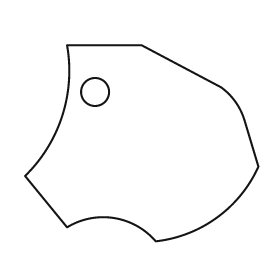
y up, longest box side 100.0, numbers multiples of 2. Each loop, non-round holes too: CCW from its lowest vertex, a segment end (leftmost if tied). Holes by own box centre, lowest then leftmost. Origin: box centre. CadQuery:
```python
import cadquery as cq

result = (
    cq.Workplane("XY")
    .moveTo(6.0, -42.0)
    .threePointArc((32.0, -32.0), (50.0, -10.0))
    .lineTo(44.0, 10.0)
    .threePointArc((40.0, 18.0), (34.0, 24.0))
    .lineTo(0.0, 42.0)
    .lineTo(-32.0, 42.0)
    .threePointArc((-34.0, 12.0), (-50.0, -14.0))
    .lineTo(-32.0, -36.0)
    .threePointArc((-12.0, -32.0), (6.0, -42.0))
    .close()
    .moveTo(-20.0, 22.0)
    .circle(6.0)
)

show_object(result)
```